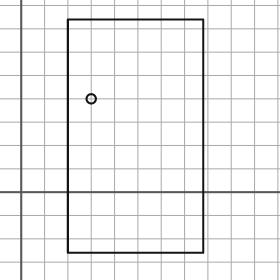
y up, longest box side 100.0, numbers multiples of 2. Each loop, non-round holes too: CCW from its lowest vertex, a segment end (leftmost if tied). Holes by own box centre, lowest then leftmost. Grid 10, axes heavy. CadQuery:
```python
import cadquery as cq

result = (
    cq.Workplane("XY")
    .moveTo(20.0, -26.0)
    .lineTo(78.0, -26.0)
    .lineTo(78.0, 74.0)
    .lineTo(20.0, 74.0)
    .close()
    .moveTo(30.0, 40.0)
    .circle(2.0)
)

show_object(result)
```